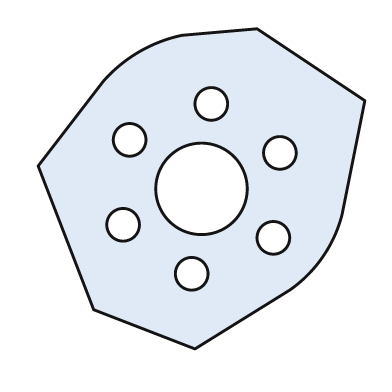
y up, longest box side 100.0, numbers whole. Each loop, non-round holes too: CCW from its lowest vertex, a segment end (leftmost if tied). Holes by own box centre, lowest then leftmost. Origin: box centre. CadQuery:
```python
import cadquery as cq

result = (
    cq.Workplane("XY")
    .moveTo(-2.0, -49.0)
    .lineTo(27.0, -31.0)
    .threePointArc((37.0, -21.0), (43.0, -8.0))
    .lineTo(50.0, 27.0)
    .lineTo(17.0, 49.0)
    .lineTo(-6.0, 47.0)
    .threePointArc((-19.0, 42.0), (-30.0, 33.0))
    .lineTo(-50.0, 7.0)
    .lineTo(-33.0, -37.0)
    .close()
    .moveTo(-3.0, -26.0)
    .circle(5.0)
    .moveTo(22.0, -15.0)
    .circle(5.0)
    .moveTo(-24.0, -11.0)
    .circle(5.0)
    .moveTo(0.0, 0.0)
    .circle(14.0)
    .moveTo(24.0, 11.0)
    .circle(5.0)
    .moveTo(-22.0, 15.0)
    .circle(5.0)
    .moveTo(3.0, 26.0)
    .circle(5.0)
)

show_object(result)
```